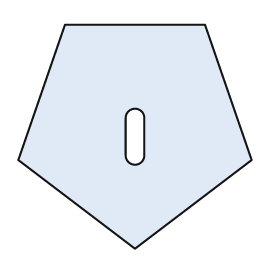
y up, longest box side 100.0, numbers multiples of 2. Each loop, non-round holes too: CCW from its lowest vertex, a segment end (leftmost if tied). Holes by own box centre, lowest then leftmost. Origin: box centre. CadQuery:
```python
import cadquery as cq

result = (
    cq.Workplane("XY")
    .moveTo(0.0, -48.0)
    .lineTo(50.0, -10.0)
    .lineTo(30.0, 48.0)
    .lineTo(-30.0, 48.0)
    .lineTo(-50.0, -10.0)
    .close()
    .moveTo(-4.0, -8.0)
    .threePointArc((0.0, -12.0), (4.0, -8.0))
    .lineTo(4.0, 8.0)
    .threePointArc((0.0, 12.0), (-4.0, 8.0))
    .close()
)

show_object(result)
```